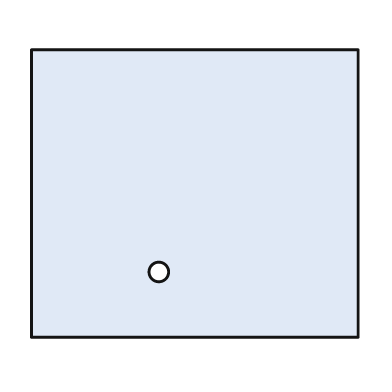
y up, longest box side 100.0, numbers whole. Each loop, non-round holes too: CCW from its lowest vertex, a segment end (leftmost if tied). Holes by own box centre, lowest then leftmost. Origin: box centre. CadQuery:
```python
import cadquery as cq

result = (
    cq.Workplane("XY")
    .moveTo(-50.0, -44.0)
    .lineTo(50.0, -44.0)
    .lineTo(50.0, 44.0)
    .lineTo(-50.0, 44.0)
    .close()
    .moveTo(-11.0, -24.0)
    .circle(3.0)
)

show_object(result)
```